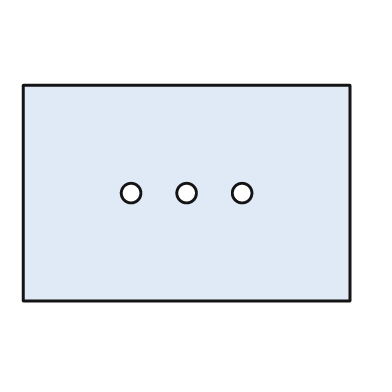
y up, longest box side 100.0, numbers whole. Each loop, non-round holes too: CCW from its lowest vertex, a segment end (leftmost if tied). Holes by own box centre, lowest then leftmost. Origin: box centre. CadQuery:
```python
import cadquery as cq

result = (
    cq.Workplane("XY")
    .moveTo(-50.0, -33.0)
    .lineTo(50.0, -33.0)
    .lineTo(50.0, 33.0)
    .lineTo(-50.0, 33.0)
    .close()
    .moveTo(-17.0, 0.0)
    .circle(3.0)
    .moveTo(0.0, 0.0)
    .circle(3.0)
    .moveTo(17.0, 0.0)
    .circle(3.0)
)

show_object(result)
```